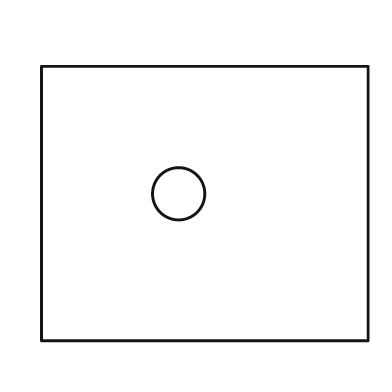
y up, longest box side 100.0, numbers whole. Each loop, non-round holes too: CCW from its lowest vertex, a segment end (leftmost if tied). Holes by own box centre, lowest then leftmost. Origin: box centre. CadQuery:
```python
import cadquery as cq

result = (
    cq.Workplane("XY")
    .moveTo(-50.0, -42.0)
    .lineTo(50.0, -42.0)
    .lineTo(50.0, 42.0)
    .lineTo(-50.0, 42.0)
    .close()
    .moveTo(-8.0, 3.0)
    .circle(8.0)
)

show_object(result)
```